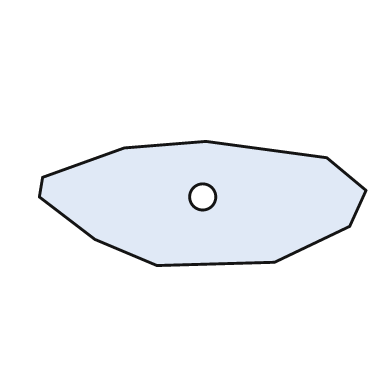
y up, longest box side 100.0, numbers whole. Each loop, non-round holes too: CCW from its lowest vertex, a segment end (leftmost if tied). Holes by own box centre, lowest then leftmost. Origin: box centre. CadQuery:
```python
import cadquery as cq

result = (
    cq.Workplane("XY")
    .moveTo(-14.0, -19.0)
    .lineTo(22.0, -18.0)
    .lineTo(45.0, -7.0)
    .lineTo(50.0, 4.0)
    .lineTo(38.0, 14.0)
    .lineTo(1.0, 19.0)
    .lineTo(-24.0, 17.0)
    .lineTo(-49.0, 8.0)
    .lineTo(-50.0, 2.0)
    .lineTo(-33.0, -11.0)
    .close()
    .moveTo(0.0, 2.0)
    .circle(4.0)
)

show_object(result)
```